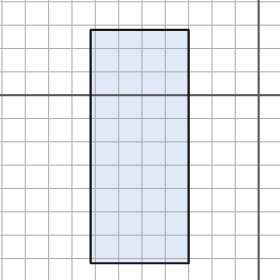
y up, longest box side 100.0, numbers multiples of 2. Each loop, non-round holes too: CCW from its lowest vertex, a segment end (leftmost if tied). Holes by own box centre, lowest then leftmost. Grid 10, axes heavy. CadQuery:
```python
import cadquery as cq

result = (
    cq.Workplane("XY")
    .moveTo(-72.0, -72.0)
    .lineTo(-30.0, -72.0)
    .lineTo(-30.0, 28.0)
    .lineTo(-72.0, 28.0)
    .close()
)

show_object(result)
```